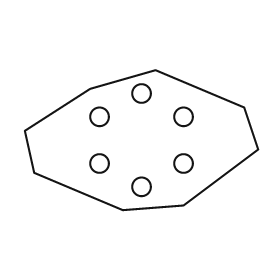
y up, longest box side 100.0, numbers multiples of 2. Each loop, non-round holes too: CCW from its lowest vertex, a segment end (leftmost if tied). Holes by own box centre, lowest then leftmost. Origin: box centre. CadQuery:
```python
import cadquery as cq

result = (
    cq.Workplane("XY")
    .moveTo(-8.0, -30.0)
    .lineTo(18.0, -28.0)
    .lineTo(50.0, -4.0)
    .lineTo(44.0, 14.0)
    .lineTo(6.0, 30.0)
    .lineTo(-22.0, 22.0)
    .lineTo(-50.0, 4.0)
    .lineTo(-46.0, -14.0)
    .close()
    .moveTo(0.0, -20.0)
    .circle(4.0)
    .moveTo(-18.0, -10.0)
    .circle(4.0)
    .moveTo(18.0, -10.0)
    .circle(4.0)
    .moveTo(-18.0, 10.0)
    .circle(4.0)
    .moveTo(18.0, 10.0)
    .circle(4.0)
    .moveTo(0.0, 20.0)
    .circle(4.0)
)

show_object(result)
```